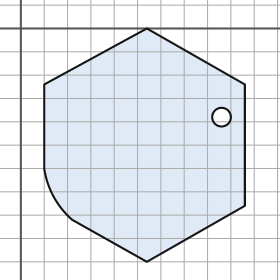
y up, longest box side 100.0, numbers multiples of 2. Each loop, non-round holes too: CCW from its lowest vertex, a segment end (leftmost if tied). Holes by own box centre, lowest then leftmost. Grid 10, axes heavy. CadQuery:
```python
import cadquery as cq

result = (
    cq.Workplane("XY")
    .moveTo(54.0, -100.0)
    .lineTo(96.0, -76.0)
    .lineTo(96.0, -24.0)
    .lineTo(54.0, 0.0)
    .lineTo(10.0, -24.0)
    .lineTo(10.0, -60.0)
    .threePointArc((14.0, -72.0), (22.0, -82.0))
    .close()
    .moveTo(86.0, -38.0)
    .circle(4.0)
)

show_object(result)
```